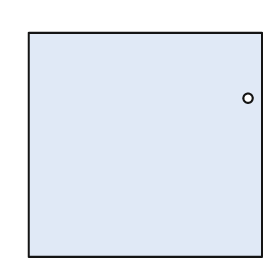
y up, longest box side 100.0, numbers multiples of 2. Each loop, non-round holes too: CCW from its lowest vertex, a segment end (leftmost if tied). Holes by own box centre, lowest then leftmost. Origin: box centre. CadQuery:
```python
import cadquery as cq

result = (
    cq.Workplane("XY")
    .moveTo(-50.0, -48.0)
    .lineTo(50.0, -48.0)
    .lineTo(50.0, 48.0)
    .lineTo(-50.0, 48.0)
    .close()
    .moveTo(44.0, 20.0)
    .circle(2.0)
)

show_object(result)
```